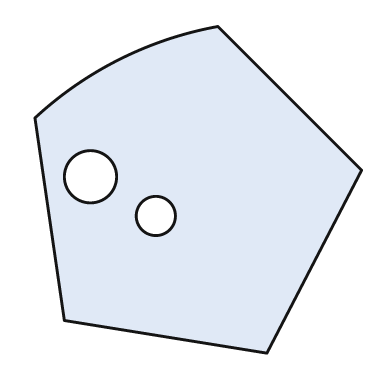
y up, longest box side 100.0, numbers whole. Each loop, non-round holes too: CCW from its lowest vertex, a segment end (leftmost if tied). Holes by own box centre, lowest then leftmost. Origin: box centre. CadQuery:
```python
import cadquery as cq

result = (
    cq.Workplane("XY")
    .moveTo(21.0, -50.0)
    .lineTo(50.0, 6.0)
    .lineTo(6.0, 50.0)
    .threePointArc((-24.0, 40.0), (-50.0, 22.0))
    .lineTo(-41.0, -40.0)
    .close()
    .moveTo(-13.0, -8.0)
    .circle(6.0)
    .moveTo(-33.0, 4.0)
    .circle(8.0)
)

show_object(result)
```